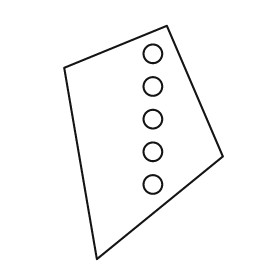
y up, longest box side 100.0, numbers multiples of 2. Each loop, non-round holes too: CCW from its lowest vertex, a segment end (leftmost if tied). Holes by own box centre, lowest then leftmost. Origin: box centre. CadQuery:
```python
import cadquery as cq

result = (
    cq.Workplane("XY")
    .moveTo(-20.0, -50.0)
    .lineTo(34.0, -6.0)
    .lineTo(10.0, 50.0)
    .lineTo(-34.0, 32.0)
    .close()
    .moveTo(4.0, -18.0)
    .circle(4.0)
    .moveTo(4.0, -4.0)
    .circle(4.0)
    .moveTo(4.0, 10.0)
    .circle(4.0)
    .moveTo(4.0, 24.0)
    .circle(4.0)
    .moveTo(4.0, 38.0)
    .circle(4.0)
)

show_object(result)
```